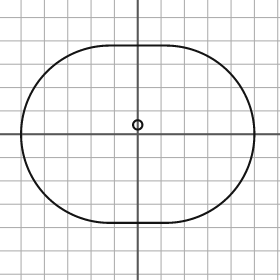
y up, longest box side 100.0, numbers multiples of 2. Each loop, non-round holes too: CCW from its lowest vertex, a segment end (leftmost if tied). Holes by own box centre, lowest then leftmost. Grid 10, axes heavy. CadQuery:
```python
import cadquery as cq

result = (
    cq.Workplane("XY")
    .moveTo(-12.0, -38.0)
    .lineTo(12.0, -38.0)
    .threePointArc((50.0, 0.0), (12.0, 38.0))
    .lineTo(-12.0, 38.0)
    .threePointArc((-50.0, 0.0), (-12.0, -38.0))
    .close()
    .moveTo(0.0, 4.0)
    .circle(2.0)
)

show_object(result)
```